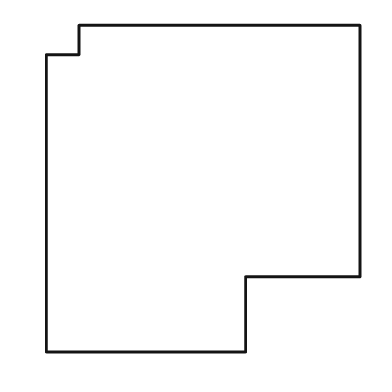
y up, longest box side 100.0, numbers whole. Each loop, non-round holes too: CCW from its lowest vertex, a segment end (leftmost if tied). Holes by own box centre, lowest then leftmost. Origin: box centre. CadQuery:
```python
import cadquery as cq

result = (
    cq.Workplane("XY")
    .moveTo(-48.0, -50.0)
    .lineTo(13.0, -50.0)
    .lineTo(13.0, -27.0)
    .lineTo(48.0, -27.0)
    .lineTo(48.0, 50.0)
    .lineTo(-38.0, 50.0)
    .lineTo(-38.0, 41.0)
    .lineTo(-48.0, 41.0)
    .close()
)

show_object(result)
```